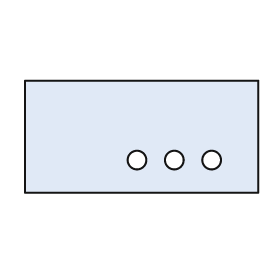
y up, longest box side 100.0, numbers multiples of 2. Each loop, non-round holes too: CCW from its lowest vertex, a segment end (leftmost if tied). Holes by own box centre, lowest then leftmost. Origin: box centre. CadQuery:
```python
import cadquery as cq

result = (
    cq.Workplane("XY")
    .moveTo(-50.0, -24.0)
    .lineTo(50.0, -24.0)
    .lineTo(50.0, 24.0)
    .lineTo(-50.0, 24.0)
    .close()
    .moveTo(-2.0, -10.0)
    .circle(4.0)
    .moveTo(14.0, -10.0)
    .circle(4.0)
    .moveTo(30.0, -10.0)
    .circle(4.0)
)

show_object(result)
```